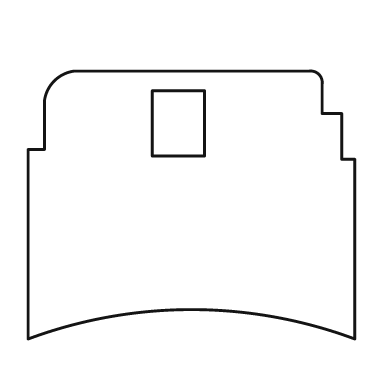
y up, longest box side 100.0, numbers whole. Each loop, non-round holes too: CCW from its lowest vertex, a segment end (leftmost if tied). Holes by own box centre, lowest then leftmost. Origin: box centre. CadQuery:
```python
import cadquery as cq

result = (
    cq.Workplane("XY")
    .moveTo(-50.0, -41.0)
    .threePointArc((0.0, -32.0), (50.0, -41.0))
    .lineTo(50.0, 14.0)
    .lineTo(46.0, 14.0)
    .lineTo(46.0, 28.0)
    .lineTo(40.0, 28.0)
    .lineTo(40.0, 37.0)
    .threePointArc((39.0, 40.0), (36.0, 41.0))
    .lineTo(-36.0, 41.0)
    .threePointArc((-42.0, 38.0), (-45.0, 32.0))
    .lineTo(-45.0, 17.0)
    .lineTo(-50.0, 17.0)
    .close()
    .moveTo(-12.0, 15.0)
    .lineTo(4.0, 15.0)
    .lineTo(4.0, 35.0)
    .lineTo(-12.0, 35.0)
    .close()
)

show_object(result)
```